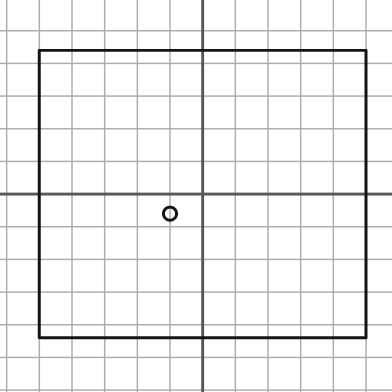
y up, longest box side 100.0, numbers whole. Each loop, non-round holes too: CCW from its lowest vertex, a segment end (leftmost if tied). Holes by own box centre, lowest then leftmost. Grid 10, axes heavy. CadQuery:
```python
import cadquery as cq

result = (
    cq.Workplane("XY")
    .moveTo(-50.0, -44.0)
    .lineTo(50.0, -44.0)
    .lineTo(50.0, 44.0)
    .lineTo(-50.0, 44.0)
    .close()
    .moveTo(-10.0, -6.0)
    .circle(2.0)
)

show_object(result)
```